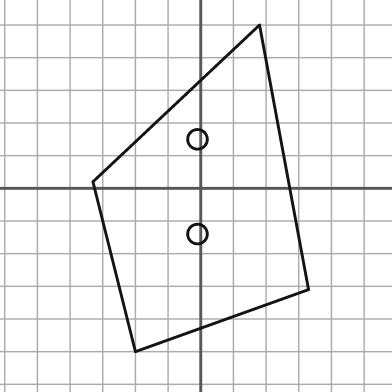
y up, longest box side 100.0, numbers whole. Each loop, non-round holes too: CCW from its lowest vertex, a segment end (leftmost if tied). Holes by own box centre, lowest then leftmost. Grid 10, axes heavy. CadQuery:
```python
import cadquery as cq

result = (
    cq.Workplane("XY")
    .moveTo(-20.0, -50.0)
    .lineTo(33.0, -31.0)
    .lineTo(18.0, 50.0)
    .lineTo(-33.0, 2.0)
    .close()
    .moveTo(-1.0, -14.0)
    .circle(3.0)
    .moveTo(-1.0, 15.0)
    .circle(3.0)
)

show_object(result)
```